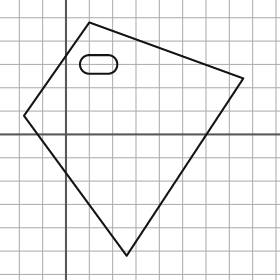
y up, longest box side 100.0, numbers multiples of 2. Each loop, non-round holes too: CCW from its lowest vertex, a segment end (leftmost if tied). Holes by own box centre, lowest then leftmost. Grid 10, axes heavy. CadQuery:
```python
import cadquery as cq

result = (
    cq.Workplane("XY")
    .moveTo(26.0, -52.0)
    .lineTo(76.0, 24.0)
    .lineTo(10.0, 48.0)
    .lineTo(-18.0, 8.0)
    .close()
    .moveTo(10.0, 26.0)
    .lineTo(18.0, 26.0)
    .threePointArc((22.0, 30.0), (18.0, 34.0))
    .lineTo(10.0, 34.0)
    .threePointArc((6.0, 30.0), (10.0, 26.0))
    .close()
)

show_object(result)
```